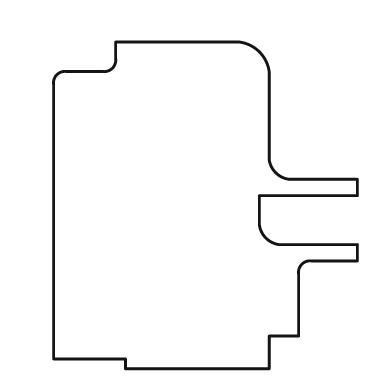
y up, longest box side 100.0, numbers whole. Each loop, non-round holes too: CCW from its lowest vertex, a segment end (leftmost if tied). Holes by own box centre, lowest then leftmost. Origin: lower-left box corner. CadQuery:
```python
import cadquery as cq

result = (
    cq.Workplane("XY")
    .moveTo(22.0, 0.0)
    .lineTo(66.0, 0.0)
    .lineTo(66.0, 10.0)
    .lineTo(75.0, 10.0)
    .lineTo(75.0, 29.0)
    .threePointArc((76.0, 32.0), (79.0, 33.0))
    .lineTo(93.0, 33.0)
    .lineTo(93.0, 38.0)
    .lineTo(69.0, 38.0)
    .threePointArc((65.0, 40.0), (63.0, 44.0))
    .lineTo(63.0, 53.0)
    .lineTo(93.0, 53.0)
    .lineTo(93.0, 58.0)
    .lineTo(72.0, 58.0)
    .threePointArc((68.0, 60.0), (66.0, 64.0))
    .lineTo(66.0, 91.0)
    .threePointArc((63.0, 97.0), (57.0, 100.0))
    .lineTo(19.0, 100.0)
    .lineTo(19.0, 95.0)
    .threePointArc((18.0, 92.0), (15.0, 91.0))
    .lineTo(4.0, 91.0)
    .threePointArc((1.0, 90.0), (0.0, 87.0))
    .lineTo(0.0, 3.0)
    .lineTo(22.0, 3.0)
    .close()
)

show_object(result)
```